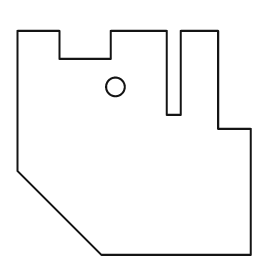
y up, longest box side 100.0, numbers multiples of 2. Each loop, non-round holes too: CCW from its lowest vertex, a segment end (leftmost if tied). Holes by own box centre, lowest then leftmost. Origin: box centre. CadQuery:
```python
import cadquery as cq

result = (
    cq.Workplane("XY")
    .moveTo(-14.0, -48.0)
    .lineTo(50.0, -48.0)
    .lineTo(50.0, 6.0)
    .lineTo(36.0, 6.0)
    .lineTo(36.0, 48.0)
    .lineTo(20.0, 48.0)
    .lineTo(20.0, 12.0)
    .lineTo(14.0, 12.0)
    .lineTo(14.0, 48.0)
    .lineTo(-10.0, 48.0)
    .lineTo(-10.0, 36.0)
    .lineTo(-32.0, 36.0)
    .lineTo(-32.0, 48.0)
    .lineTo(-50.0, 48.0)
    .lineTo(-50.0, -12.0)
    .close()
    .moveTo(-8.0, 24.0)
    .circle(4.0)
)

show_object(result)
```